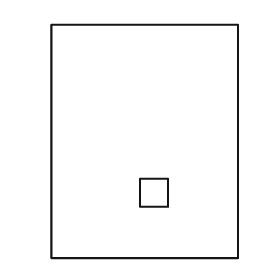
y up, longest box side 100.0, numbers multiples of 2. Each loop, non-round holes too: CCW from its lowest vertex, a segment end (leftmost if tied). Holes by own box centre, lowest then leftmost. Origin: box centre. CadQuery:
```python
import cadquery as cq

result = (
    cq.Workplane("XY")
    .moveTo(-40.0, -50.0)
    .lineTo(40.0, -50.0)
    .lineTo(40.0, 50.0)
    .lineTo(-40.0, 50.0)
    .close()
    .moveTo(-2.0, -28.0)
    .lineTo(10.0, -28.0)
    .lineTo(10.0, -16.0)
    .lineTo(-2.0, -16.0)
    .close()
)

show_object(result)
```